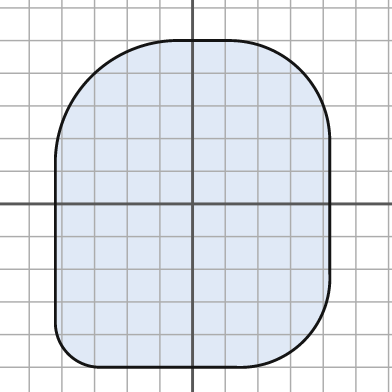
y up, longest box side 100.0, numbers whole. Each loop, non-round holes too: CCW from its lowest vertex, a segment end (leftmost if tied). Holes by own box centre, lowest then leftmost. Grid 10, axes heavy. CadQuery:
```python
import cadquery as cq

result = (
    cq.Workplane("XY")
    .moveTo(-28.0, -50.0)
    .lineTo(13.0, -50.0)
    .threePointArc((34.0, -42.0), (42.0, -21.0))
    .lineTo(42.0, 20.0)
    .threePointArc((33.0, 41.0), (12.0, 50.0))
    .lineTo(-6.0, 50.0)
    .threePointArc((-31.0, 39.0), (-42.0, 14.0))
    .lineTo(-42.0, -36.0)
    .threePointArc((-38.0, -46.0), (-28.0, -50.0))
    .close()
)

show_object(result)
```